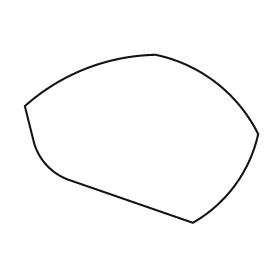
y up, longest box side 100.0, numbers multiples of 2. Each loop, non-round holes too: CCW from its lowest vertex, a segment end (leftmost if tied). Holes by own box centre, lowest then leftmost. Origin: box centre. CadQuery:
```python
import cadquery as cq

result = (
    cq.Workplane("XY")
    .moveTo(22.0, -36.0)
    .threePointArc((40.0, -20.0), (50.0, 2.0))
    .threePointArc((32.0, 24.0), (6.0, 36.0))
    .threePointArc((-24.0, 30.0), (-50.0, 14.0))
    .lineTo(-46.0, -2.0)
    .threePointArc((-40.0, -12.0), (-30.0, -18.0))
    .close()
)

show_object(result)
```